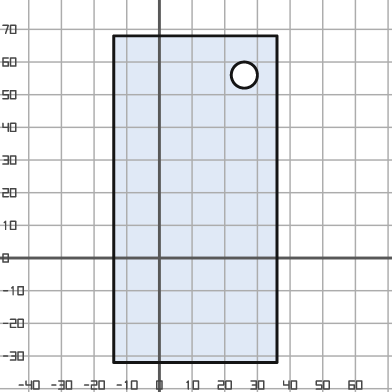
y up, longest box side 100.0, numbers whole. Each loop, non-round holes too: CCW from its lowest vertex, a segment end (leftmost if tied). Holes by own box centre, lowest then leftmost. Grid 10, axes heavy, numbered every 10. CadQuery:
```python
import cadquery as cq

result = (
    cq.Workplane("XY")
    .moveTo(-14.0, -32.0)
    .lineTo(36.0, -32.0)
    .lineTo(36.0, 68.0)
    .lineTo(-14.0, 68.0)
    .close()
    .moveTo(26.0, 56.0)
    .circle(4.0)
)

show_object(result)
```